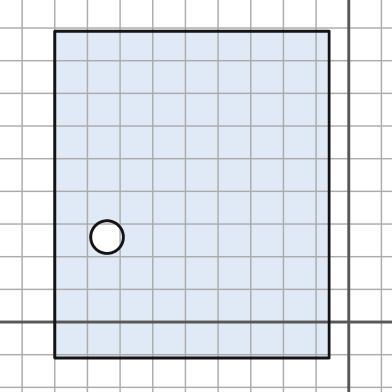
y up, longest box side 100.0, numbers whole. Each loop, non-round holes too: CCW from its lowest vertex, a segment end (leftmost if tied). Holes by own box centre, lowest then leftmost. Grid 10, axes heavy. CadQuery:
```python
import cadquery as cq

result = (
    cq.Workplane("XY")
    .moveTo(-90.0, -11.0)
    .lineTo(-6.0, -11.0)
    .lineTo(-6.0, 89.0)
    .lineTo(-90.0, 89.0)
    .close()
    .moveTo(-74.0, 26.0)
    .circle(5.0)
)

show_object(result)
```